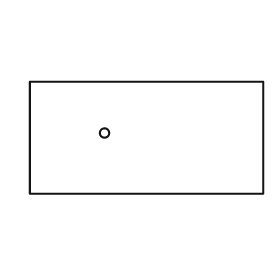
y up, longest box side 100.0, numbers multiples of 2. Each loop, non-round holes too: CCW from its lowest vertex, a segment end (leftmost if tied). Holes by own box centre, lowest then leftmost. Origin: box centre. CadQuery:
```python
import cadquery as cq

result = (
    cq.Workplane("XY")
    .moveTo(-50.0, -24.0)
    .lineTo(50.0, -24.0)
    .lineTo(50.0, 24.0)
    .lineTo(-50.0, 24.0)
    .close()
    .moveTo(-18.0, 2.0)
    .circle(2.0)
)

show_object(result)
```